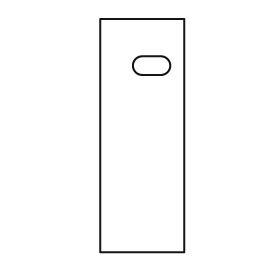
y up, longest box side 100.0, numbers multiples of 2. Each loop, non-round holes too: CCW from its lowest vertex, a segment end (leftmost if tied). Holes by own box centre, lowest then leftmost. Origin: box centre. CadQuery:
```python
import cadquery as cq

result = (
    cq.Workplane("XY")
    .moveTo(-18.0, -50.0)
    .lineTo(18.0, -50.0)
    .lineTo(18.0, 50.0)
    .lineTo(-18.0, 50.0)
    .close()
    .moveTo(0.0, 26.0)
    .lineTo(8.0, 26.0)
    .threePointArc((12.0, 30.0), (8.0, 34.0))
    .lineTo(0.0, 34.0)
    .threePointArc((-4.0, 30.0), (0.0, 26.0))
    .close()
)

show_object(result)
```